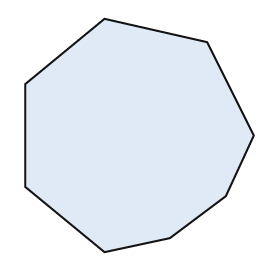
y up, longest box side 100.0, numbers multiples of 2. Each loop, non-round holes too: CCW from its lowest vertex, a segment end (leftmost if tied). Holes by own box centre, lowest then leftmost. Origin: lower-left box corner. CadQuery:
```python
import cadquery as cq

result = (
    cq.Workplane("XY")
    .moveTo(34.0, 0.0)
    .lineTo(62.0, 6.0)
    .lineTo(86.0, 24.0)
    .lineTo(98.0, 50.0)
    .lineTo(78.0, 90.0)
    .lineTo(34.0, 100.0)
    .lineTo(0.0, 72.0)
    .lineTo(0.0, 28.0)
    .close()
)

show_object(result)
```